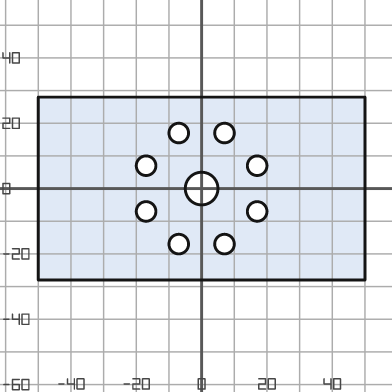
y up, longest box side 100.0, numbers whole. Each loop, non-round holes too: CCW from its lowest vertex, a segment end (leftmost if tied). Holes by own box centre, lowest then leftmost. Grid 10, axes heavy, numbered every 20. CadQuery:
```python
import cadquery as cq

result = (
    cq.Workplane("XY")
    .moveTo(-50.0, -28.0)
    .lineTo(50.0, -28.0)
    .lineTo(50.0, 28.0)
    .lineTo(-50.0, 28.0)
    .close()
    .moveTo(-7.0, -17.0)
    .circle(3.0)
    .moveTo(7.0, -17.0)
    .circle(3.0)
    .moveTo(-17.0, -7.0)
    .circle(3.0)
    .moveTo(17.0, -7.0)
    .circle(3.0)
    .moveTo(0.0, 0.0)
    .circle(5.0)
    .moveTo(-17.0, 7.0)
    .circle(3.0)
    .moveTo(17.0, 7.0)
    .circle(3.0)
    .moveTo(-7.0, 17.0)
    .circle(3.0)
    .moveTo(7.0, 17.0)
    .circle(3.0)
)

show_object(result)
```